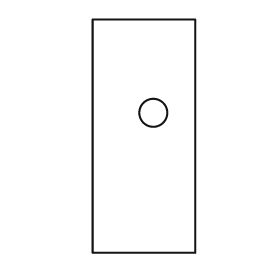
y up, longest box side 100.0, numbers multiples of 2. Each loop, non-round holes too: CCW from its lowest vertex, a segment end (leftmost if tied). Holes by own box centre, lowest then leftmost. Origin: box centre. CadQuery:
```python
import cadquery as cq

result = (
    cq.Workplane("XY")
    .moveTo(-22.0, -50.0)
    .lineTo(22.0, -50.0)
    .lineTo(22.0, 50.0)
    .lineTo(-22.0, 50.0)
    .close()
    .moveTo(4.0, 10.0)
    .circle(6.0)
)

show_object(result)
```